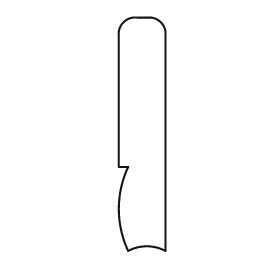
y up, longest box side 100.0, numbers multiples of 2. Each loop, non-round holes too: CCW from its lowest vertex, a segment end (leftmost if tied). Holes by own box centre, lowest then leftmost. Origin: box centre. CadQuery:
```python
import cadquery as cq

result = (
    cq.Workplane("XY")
    .moveTo(-6.0, -50.0)
    .threePointArc((2.0, -48.0), (10.0, -50.0))
    .lineTo(10.0, 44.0)
    .threePointArc((8.0, 48.0), (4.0, 50.0))
    .lineTo(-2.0, 50.0)
    .threePointArc((-8.0, 48.0), (-10.0, 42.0))
    .lineTo(-10.0, -14.0)
    .lineTo(-6.0, -14.0)
    .threePointArc((-10.0, -32.0), (-6.0, -50.0))
    .close()
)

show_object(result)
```